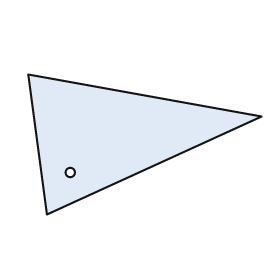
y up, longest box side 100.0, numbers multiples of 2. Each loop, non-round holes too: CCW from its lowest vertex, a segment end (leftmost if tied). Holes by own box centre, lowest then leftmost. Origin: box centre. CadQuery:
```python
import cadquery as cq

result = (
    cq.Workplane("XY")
    .moveTo(-42.0, -30.0)
    .lineTo(50.0, 12.0)
    .lineTo(-50.0, 30.0)
    .close()
    .moveTo(-32.0, -12.0)
    .circle(2.0)
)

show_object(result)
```